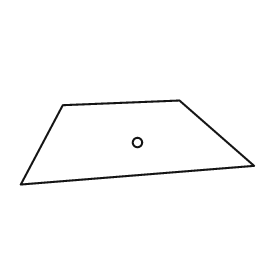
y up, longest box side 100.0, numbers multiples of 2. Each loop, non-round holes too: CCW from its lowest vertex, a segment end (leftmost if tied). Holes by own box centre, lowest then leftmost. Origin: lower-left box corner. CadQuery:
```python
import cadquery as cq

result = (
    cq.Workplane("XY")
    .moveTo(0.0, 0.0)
    .lineTo(100.0, 8.0)
    .lineTo(68.0, 36.0)
    .lineTo(18.0, 34.0)
    .close()
    .moveTo(50.0, 18.0)
    .circle(2.0)
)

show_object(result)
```